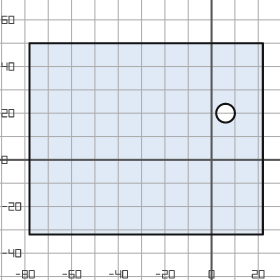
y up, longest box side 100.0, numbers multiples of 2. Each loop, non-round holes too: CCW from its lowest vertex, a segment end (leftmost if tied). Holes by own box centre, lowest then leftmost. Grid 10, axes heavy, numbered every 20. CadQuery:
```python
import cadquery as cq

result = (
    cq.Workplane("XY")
    .moveTo(-78.0, -32.0)
    .lineTo(22.0, -32.0)
    .lineTo(22.0, 50.0)
    .lineTo(-78.0, 50.0)
    .close()
    .moveTo(6.0, 20.0)
    .circle(4.0)
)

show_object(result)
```